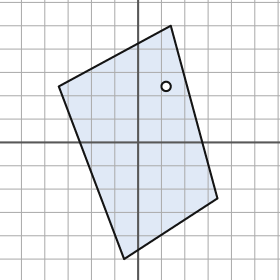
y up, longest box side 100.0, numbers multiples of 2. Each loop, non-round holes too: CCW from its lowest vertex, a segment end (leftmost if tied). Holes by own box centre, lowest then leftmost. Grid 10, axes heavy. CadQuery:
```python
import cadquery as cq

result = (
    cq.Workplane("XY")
    .moveTo(-6.0, -50.0)
    .lineTo(34.0, -24.0)
    .lineTo(14.0, 50.0)
    .lineTo(-34.0, 24.0)
    .close()
    .moveTo(12.0, 24.0)
    .circle(2.0)
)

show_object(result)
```